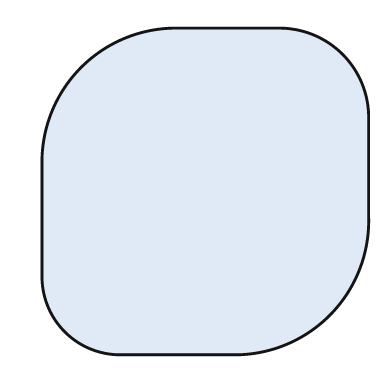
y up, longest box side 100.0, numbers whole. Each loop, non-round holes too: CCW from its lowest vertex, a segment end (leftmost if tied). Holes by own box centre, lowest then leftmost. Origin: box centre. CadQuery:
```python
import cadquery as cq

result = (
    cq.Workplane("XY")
    .moveTo(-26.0, -50.0)
    .lineTo(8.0, -50.0)
    .threePointArc((38.0, -38.0), (50.0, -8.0))
    .lineTo(50.0, 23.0)
    .threePointArc((42.0, 42.0), (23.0, 50.0))
    .lineTo(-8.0, 50.0)
    .threePointArc((-38.0, 38.0), (-50.0, 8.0))
    .lineTo(-50.0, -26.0)
    .threePointArc((-43.0, -43.0), (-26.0, -50.0))
    .close()
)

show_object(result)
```